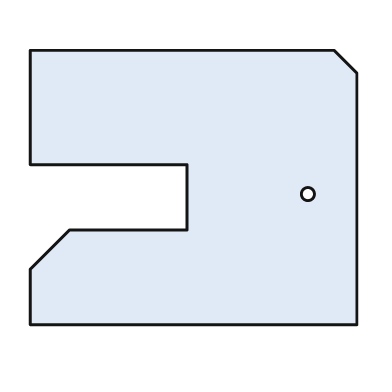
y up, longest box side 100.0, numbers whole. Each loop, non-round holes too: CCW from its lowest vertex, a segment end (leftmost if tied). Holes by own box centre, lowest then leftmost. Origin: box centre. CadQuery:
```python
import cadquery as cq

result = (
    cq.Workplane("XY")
    .moveTo(-50.0, -42.0)
    .lineTo(50.0, -42.0)
    .lineTo(50.0, 35.0)
    .lineTo(43.0, 42.0)
    .lineTo(-50.0, 42.0)
    .lineTo(-50.0, 7.0)
    .lineTo(-2.0, 7.0)
    .lineTo(-2.0, -13.0)
    .lineTo(-38.0, -13.0)
    .lineTo(-50.0, -25.0)
    .close()
    .moveTo(35.0, -2.0)
    .circle(2.0)
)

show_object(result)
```